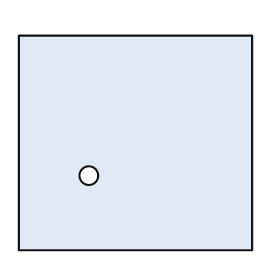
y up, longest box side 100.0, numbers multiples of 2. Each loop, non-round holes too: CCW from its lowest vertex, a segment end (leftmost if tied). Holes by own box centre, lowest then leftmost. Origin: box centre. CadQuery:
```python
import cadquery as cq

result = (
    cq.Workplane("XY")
    .moveTo(-50.0, -46.0)
    .lineTo(50.0, -46.0)
    .lineTo(50.0, 46.0)
    .lineTo(-50.0, 46.0)
    .close()
    .moveTo(-20.0, -14.0)
    .circle(4.0)
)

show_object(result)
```